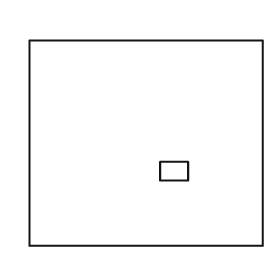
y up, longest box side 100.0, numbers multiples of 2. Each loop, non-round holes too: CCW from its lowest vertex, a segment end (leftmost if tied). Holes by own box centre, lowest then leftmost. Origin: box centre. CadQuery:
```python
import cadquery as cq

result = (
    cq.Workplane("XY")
    .moveTo(-50.0, -44.0)
    .lineTo(50.0, -44.0)
    .lineTo(50.0, 44.0)
    .lineTo(-50.0, 44.0)
    .close()
    .moveTo(6.0, -16.0)
    .lineTo(18.0, -16.0)
    .lineTo(18.0, -8.0)
    .lineTo(6.0, -8.0)
    .close()
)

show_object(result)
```